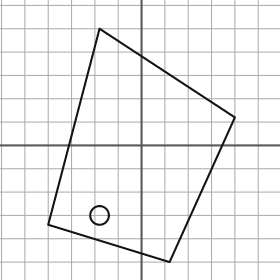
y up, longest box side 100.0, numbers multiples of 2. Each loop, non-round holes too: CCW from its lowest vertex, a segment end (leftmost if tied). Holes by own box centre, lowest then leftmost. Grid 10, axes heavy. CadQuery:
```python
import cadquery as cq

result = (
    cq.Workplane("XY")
    .moveTo(12.0, -50.0)
    .lineTo(40.0, 12.0)
    .lineTo(-18.0, 50.0)
    .lineTo(-40.0, -34.0)
    .close()
    .moveTo(-18.0, -30.0)
    .circle(4.0)
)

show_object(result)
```